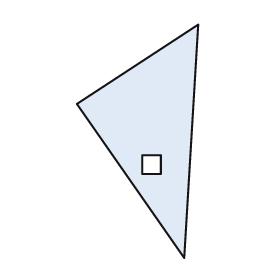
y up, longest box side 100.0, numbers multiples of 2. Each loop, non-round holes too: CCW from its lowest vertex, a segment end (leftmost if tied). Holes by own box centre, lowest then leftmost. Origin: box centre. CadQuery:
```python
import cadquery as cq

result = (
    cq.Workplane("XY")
    .moveTo(20.0, -50.0)
    .lineTo(26.0, 50.0)
    .lineTo(-26.0, 16.0)
    .close()
    .moveTo(2.0, -14.0)
    .lineTo(10.0, -14.0)
    .lineTo(10.0, -6.0)
    .lineTo(2.0, -6.0)
    .close()
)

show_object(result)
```